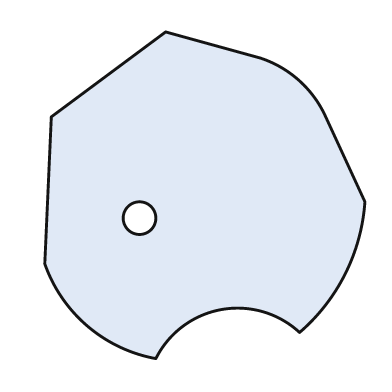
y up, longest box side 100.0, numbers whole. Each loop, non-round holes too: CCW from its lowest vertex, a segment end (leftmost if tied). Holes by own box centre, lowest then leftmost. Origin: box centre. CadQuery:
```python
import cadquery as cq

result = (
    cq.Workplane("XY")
    .moveTo(-15.0, -50.0)
    .threePointArc((5.0, -35.0), (29.0, -42.0))
    .threePointArc((43.0, -24.0), (49.0, -2.0))
    .lineTo(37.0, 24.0)
    .threePointArc((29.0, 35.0), (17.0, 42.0))
    .lineTo(-12.0, 50.0)
    .lineTo(-47.0, 24.0)
    .lineTo(-49.0, -21.0)
    .threePointArc((-36.0, -40.0), (-15.0, -50.0))
    .close()
    .moveTo(-20.0, -7.0)
    .circle(5.0)
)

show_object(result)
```